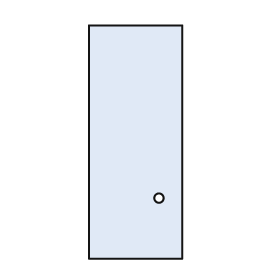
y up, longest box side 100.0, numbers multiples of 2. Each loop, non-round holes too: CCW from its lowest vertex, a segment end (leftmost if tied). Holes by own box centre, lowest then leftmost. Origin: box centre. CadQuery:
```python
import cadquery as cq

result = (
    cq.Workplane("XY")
    .moveTo(-20.0, -50.0)
    .lineTo(20.0, -50.0)
    .lineTo(20.0, 50.0)
    .lineTo(-20.0, 50.0)
    .close()
    .moveTo(10.0, -24.0)
    .circle(2.0)
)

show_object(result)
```